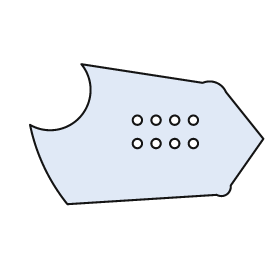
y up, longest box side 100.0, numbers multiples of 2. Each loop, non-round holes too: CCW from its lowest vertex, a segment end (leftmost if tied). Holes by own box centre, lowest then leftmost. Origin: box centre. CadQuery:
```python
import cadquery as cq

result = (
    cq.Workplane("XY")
    .moveTo(-34.0, -30.0)
    .lineTo(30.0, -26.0)
    .threePointArc((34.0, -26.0), (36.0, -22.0))
    .lineTo(50.0, -2.0)
    .lineTo(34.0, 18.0)
    .threePointArc((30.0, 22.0), (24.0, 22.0))
    .lineTo(-28.0, 30.0)
    .threePointArc((-28.0, 8.0), (-50.0, 4.0))
    .threePointArc((-44.0, -14.0), (-34.0, -30.0))
    .close()
    .moveTo(-4.0, -4.0)
    .circle(2.0)
    .moveTo(4.0, -4.0)
    .circle(2.0)
    .moveTo(12.0, -4.0)
    .circle(2.0)
    .moveTo(20.0, -4.0)
    .circle(2.0)
    .moveTo(-4.0, 6.0)
    .circle(2.0)
    .moveTo(4.0, 6.0)
    .circle(2.0)
    .moveTo(12.0, 6.0)
    .circle(2.0)
    .moveTo(20.0, 6.0)
    .circle(2.0)
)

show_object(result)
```